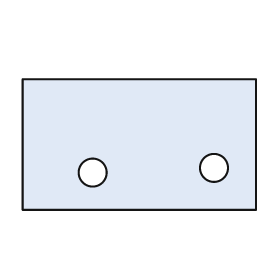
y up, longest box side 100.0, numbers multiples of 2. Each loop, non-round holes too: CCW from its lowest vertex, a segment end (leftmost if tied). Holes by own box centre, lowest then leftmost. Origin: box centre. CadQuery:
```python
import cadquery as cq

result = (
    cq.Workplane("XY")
    .moveTo(-50.0, -28.0)
    .lineTo(50.0, -28.0)
    .lineTo(50.0, 28.0)
    .lineTo(-50.0, 28.0)
    .close()
    .moveTo(-20.0, -12.0)
    .circle(6.0)
    .moveTo(32.0, -10.0)
    .circle(6.0)
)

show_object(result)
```